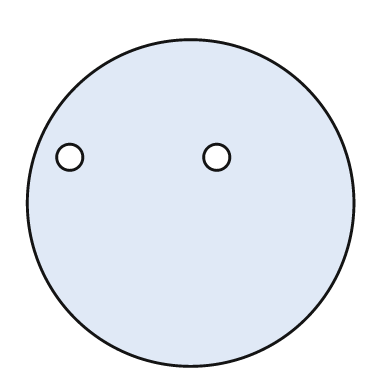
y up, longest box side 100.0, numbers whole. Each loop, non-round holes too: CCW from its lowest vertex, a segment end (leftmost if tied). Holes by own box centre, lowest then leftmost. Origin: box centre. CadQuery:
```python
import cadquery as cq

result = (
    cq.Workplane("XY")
    .moveTo(0.0, 0.0)
    .circle(50.0)
    .moveTo(-37.0, 14.0)
    .circle(4.0)
    .moveTo(8.0, 14.0)
    .circle(4.0)
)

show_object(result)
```